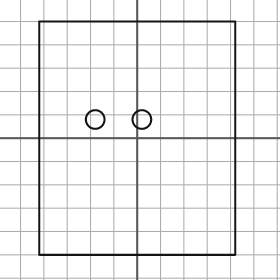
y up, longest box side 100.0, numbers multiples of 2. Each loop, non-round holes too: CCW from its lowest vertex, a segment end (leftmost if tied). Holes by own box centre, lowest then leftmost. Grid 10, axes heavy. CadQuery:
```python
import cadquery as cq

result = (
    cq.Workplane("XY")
    .moveTo(-42.0, -50.0)
    .lineTo(42.0, -50.0)
    .lineTo(42.0, 50.0)
    .lineTo(-42.0, 50.0)
    .close()
    .moveTo(-18.0, 8.0)
    .circle(4.0)
    .moveTo(2.0, 8.0)
    .circle(4.0)
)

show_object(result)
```